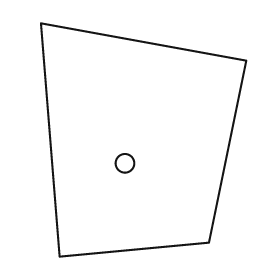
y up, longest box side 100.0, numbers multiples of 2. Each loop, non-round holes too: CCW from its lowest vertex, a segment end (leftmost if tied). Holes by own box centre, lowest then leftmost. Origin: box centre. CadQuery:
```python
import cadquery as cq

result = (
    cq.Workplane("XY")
    .moveTo(-36.0, -50.0)
    .lineTo(28.0, -44.0)
    .lineTo(44.0, 34.0)
    .lineTo(-44.0, 50.0)
    .close()
    .moveTo(-8.0, -10.0)
    .circle(4.0)
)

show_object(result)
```